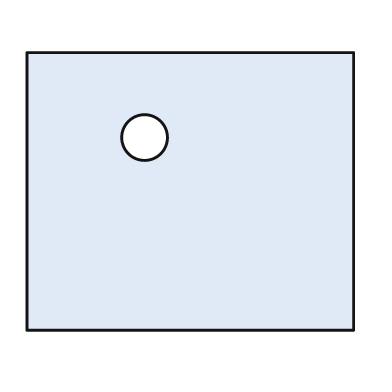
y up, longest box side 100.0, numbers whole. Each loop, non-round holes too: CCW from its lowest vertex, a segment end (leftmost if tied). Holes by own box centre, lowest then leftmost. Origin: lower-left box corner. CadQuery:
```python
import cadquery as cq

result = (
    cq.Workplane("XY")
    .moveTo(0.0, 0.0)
    .lineTo(100.0, 0.0)
    .lineTo(100.0, 85.0)
    .lineTo(0.0, 85.0)
    .close()
    .moveTo(36.0, 59.0)
    .circle(7.0)
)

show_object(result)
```